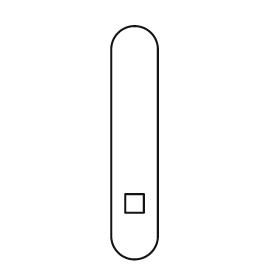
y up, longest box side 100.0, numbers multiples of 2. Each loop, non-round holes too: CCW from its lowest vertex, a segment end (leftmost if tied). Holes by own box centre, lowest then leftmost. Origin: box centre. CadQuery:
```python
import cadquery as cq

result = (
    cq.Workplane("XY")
    .moveTo(-10.0, -40.0)
    .threePointArc((0.0, -50.0), (10.0, -40.0))
    .lineTo(10.0, 40.0)
    .threePointArc((0.0, 50.0), (-10.0, 40.0))
    .close()
    .moveTo(-4.0, -30.0)
    .lineTo(4.0, -30.0)
    .lineTo(4.0, -22.0)
    .lineTo(-4.0, -22.0)
    .close()
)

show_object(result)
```